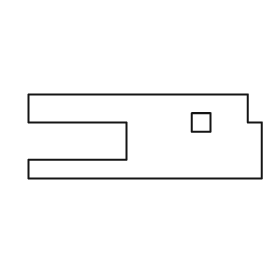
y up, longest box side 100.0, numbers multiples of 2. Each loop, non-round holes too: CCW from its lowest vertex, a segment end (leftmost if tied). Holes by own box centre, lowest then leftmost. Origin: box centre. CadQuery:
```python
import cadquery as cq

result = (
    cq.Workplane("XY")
    .moveTo(-50.0, -18.0)
    .lineTo(50.0, -18.0)
    .lineTo(50.0, 6.0)
    .lineTo(44.0, 6.0)
    .lineTo(44.0, 18.0)
    .lineTo(-50.0, 18.0)
    .lineTo(-50.0, 6.0)
    .lineTo(-8.0, 6.0)
    .lineTo(-8.0, -10.0)
    .lineTo(-50.0, -10.0)
    .close()
    .moveTo(20.0, 2.0)
    .lineTo(28.0, 2.0)
    .lineTo(28.0, 10.0)
    .lineTo(20.0, 10.0)
    .close()
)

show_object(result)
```